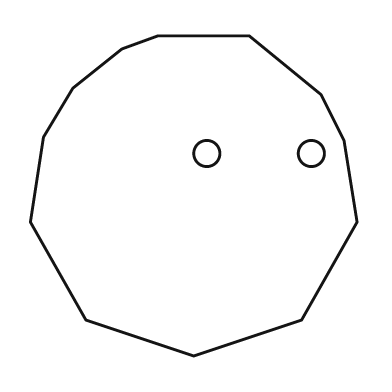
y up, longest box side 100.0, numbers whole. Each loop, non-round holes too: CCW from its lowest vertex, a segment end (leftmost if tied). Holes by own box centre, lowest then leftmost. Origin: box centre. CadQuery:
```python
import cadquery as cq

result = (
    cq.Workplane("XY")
    .moveTo(0.0, -49.0)
    .lineTo(33.0, -38.0)
    .lineTo(50.0, -8.0)
    .lineTo(46.0, 17.0)
    .lineTo(39.0, 31.0)
    .lineTo(17.0, 49.0)
    .lineTo(-11.0, 49.0)
    .lineTo(-22.0, 45.0)
    .lineTo(-37.0, 33.0)
    .lineTo(-46.0, 18.0)
    .lineTo(-50.0, -8.0)
    .lineTo(-33.0, -38.0)
    .close()
    .moveTo(4.0, 13.0)
    .circle(4.0)
    .moveTo(36.0, 13.0)
    .circle(4.0)
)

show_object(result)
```